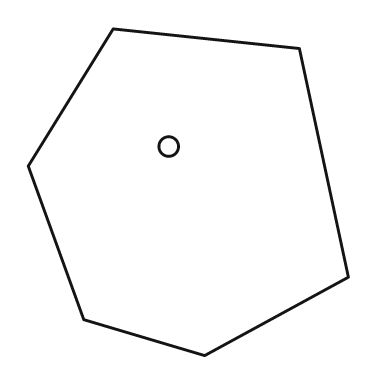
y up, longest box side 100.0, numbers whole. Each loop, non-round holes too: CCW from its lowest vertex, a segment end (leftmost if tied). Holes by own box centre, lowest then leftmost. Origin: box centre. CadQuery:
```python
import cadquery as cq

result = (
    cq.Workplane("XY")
    .moveTo(5.0, -50.0)
    .lineTo(49.0, -26.0)
    .lineTo(34.0, 44.0)
    .lineTo(-23.0, 50.0)
    .lineTo(-49.0, 8.0)
    .lineTo(-32.0, -39.0)
    .close()
    .moveTo(-6.0, 14.0)
    .circle(3.0)
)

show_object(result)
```